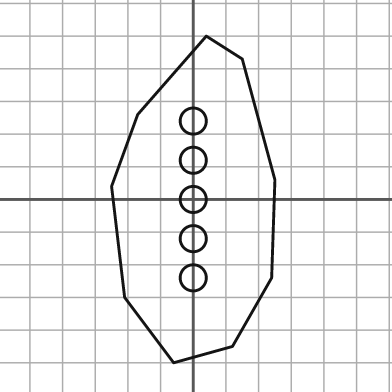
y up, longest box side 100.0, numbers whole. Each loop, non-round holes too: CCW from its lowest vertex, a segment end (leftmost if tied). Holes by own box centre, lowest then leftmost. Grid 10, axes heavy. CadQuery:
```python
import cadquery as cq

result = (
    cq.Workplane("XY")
    .moveTo(-6.0, -50.0)
    .lineTo(12.0, -45.0)
    .lineTo(24.0, -24.0)
    .lineTo(25.0, 6.0)
    .lineTo(15.0, 43.0)
    .lineTo(4.0, 50.0)
    .lineTo(-17.0, 26.0)
    .lineTo(-25.0, 4.0)
    .lineTo(-21.0, -30.0)
    .close()
    .moveTo(0.0, -24.0)
    .circle(4.0)
    .moveTo(0.0, -12.0)
    .circle(4.0)
    .moveTo(0.0, 0.0)
    .circle(4.0)
    .moveTo(0.0, 12.0)
    .circle(4.0)
    .moveTo(0.0, 24.0)
    .circle(4.0)
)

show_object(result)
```